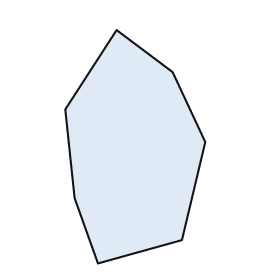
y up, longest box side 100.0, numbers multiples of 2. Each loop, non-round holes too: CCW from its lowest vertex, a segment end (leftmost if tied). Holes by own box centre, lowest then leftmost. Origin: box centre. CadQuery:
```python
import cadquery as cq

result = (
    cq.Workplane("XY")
    .moveTo(-16.0, -50.0)
    .lineTo(20.0, -40.0)
    .lineTo(30.0, 2.0)
    .lineTo(16.0, 32.0)
    .lineTo(-8.0, 50.0)
    .lineTo(-30.0, 16.0)
    .lineTo(-26.0, -22.0)
    .close()
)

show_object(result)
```